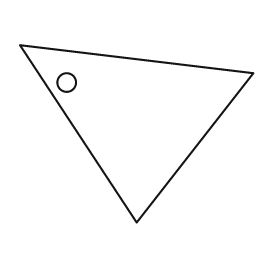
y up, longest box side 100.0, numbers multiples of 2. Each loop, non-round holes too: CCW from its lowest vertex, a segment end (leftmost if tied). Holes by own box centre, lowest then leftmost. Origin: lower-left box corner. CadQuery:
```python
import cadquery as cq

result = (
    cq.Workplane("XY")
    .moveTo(50.0, 0.0)
    .lineTo(100.0, 64.0)
    .lineTo(0.0, 76.0)
    .close()
    .moveTo(20.0, 60.0)
    .circle(4.0)
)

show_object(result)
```